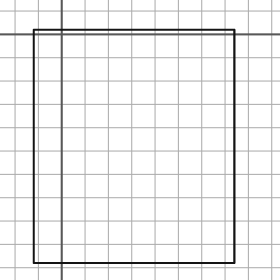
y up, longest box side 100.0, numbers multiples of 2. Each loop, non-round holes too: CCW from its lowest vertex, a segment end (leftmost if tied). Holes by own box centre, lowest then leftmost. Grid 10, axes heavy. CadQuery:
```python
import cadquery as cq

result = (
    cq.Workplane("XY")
    .moveTo(-12.0, -98.0)
    .lineTo(74.0, -98.0)
    .lineTo(74.0, 2.0)
    .lineTo(-12.0, 2.0)
    .close()
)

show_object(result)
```